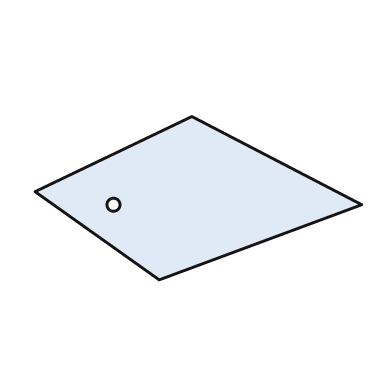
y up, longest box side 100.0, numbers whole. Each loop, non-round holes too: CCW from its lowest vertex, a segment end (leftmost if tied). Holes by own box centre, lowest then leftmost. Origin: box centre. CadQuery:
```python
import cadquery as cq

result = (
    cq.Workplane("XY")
    .moveTo(-12.0, -25.0)
    .lineTo(50.0, -2.0)
    .lineTo(-2.0, 25.0)
    .lineTo(-50.0, 2.0)
    .close()
    .moveTo(-26.0, -2.0)
    .circle(2.0)
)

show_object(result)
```